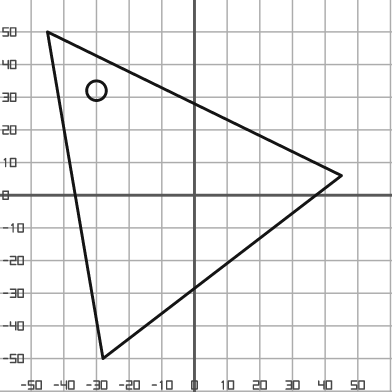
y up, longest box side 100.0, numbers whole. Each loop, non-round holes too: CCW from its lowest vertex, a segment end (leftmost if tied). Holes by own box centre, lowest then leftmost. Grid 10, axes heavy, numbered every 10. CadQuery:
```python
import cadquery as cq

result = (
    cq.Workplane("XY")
    .moveTo(-28.0, -50.0)
    .lineTo(45.0, 6.0)
    .lineTo(-45.0, 50.0)
    .close()
    .moveTo(-30.0, 32.0)
    .circle(3.0)
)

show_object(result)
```